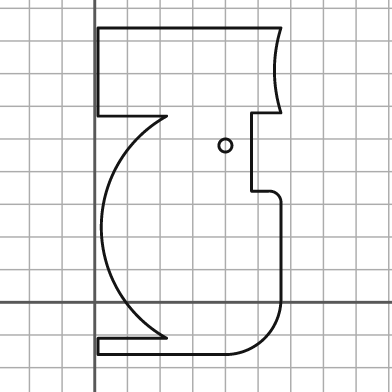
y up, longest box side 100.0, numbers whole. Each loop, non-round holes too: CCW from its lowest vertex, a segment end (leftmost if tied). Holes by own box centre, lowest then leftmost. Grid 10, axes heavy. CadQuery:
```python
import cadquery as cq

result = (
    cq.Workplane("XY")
    .moveTo(1.0, -16.0)
    .lineTo(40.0, -16.0)
    .threePointArc((52.0, -11.0), (57.0, 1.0))
    .lineTo(57.0, 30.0)
    .threePointArc((56.0, 33.0), (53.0, 34.0))
    .lineTo(48.0, 34.0)
    .lineTo(48.0, 58.0)
    .lineTo(57.0, 58.0)
    .threePointArc((55.0, 71.0), (57.0, 84.0))
    .lineTo(1.0, 84.0)
    .lineTo(1.0, 57.0)
    .lineTo(22.0, 57.0)
    .threePointArc((2.0, 23.0), (22.0, -11.0))
    .lineTo(1.0, -11.0)
    .close()
    .moveTo(40.0, 48.0)
    .circle(2.0)
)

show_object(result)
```